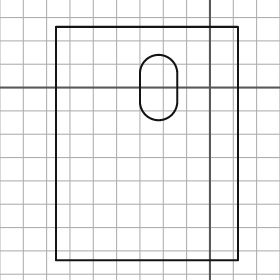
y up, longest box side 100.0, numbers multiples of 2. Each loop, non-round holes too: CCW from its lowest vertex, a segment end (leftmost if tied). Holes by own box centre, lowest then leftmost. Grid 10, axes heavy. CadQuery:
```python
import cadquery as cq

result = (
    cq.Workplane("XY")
    .moveTo(-66.0, -74.0)
    .lineTo(12.0, -74.0)
    .lineTo(12.0, 26.0)
    .lineTo(-66.0, 26.0)
    .close()
    .moveTo(-30.0, -6.0)
    .threePointArc((-22.0, -14.0), (-14.0, -6.0))
    .lineTo(-14.0, 6.0)
    .threePointArc((-22.0, 14.0), (-30.0, 6.0))
    .close()
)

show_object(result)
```